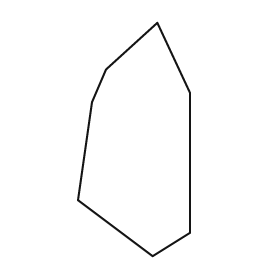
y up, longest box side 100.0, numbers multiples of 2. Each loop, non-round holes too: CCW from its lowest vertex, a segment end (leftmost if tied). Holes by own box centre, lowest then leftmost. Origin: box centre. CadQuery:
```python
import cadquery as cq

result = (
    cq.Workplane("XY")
    .moveTo(8.0, -50.0)
    .lineTo(24.0, -40.0)
    .lineTo(24.0, 20.0)
    .lineTo(10.0, 50.0)
    .lineTo(-12.0, 30.0)
    .lineTo(-18.0, 16.0)
    .lineTo(-24.0, -26.0)
    .close()
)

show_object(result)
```